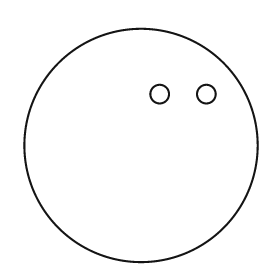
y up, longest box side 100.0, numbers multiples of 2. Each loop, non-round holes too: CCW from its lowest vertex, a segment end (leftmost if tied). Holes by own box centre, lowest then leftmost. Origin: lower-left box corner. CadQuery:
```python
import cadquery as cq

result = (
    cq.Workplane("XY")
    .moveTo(50.0, 50.0)
    .circle(50.0)
    .moveTo(58.0, 72.0)
    .circle(4.0)
    .moveTo(78.0, 72.0)
    .circle(4.0)
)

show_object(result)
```